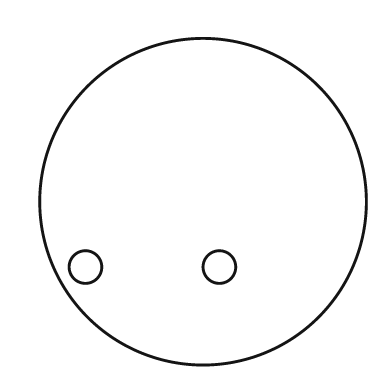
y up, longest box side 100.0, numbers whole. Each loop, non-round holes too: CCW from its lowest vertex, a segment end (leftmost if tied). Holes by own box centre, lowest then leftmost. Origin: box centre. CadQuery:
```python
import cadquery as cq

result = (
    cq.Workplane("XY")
    .moveTo(0.0, 0.0)
    .circle(50.0)
    .moveTo(-36.0, -20.0)
    .circle(5.0)
    .moveTo(5.0, -20.0)
    .circle(5.0)
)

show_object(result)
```